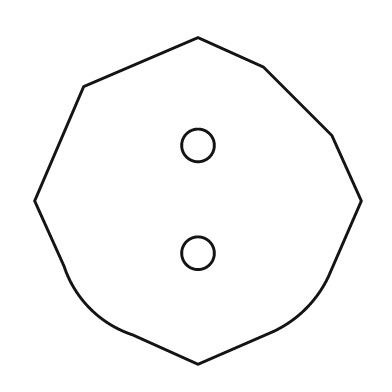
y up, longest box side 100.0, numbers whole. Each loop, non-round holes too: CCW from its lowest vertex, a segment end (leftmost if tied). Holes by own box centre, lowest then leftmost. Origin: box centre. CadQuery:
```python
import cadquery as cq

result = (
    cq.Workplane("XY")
    .moveTo(0.0, -50.0)
    .lineTo(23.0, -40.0)
    .threePointArc((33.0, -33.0), (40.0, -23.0))
    .lineTo(50.0, 0.0)
    .lineTo(41.0, 20.0)
    .lineTo(20.0, 41.0)
    .lineTo(0.0, 50.0)
    .lineTo(-35.0, 35.0)
    .lineTo(-50.0, 0.0)
    .lineTo(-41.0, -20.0)
    .threePointArc((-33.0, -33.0), (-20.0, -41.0))
    .close()
    .moveTo(0.0, -16.0)
    .circle(5.0)
    .moveTo(0.0, 17.0)
    .circle(5.0)
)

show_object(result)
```